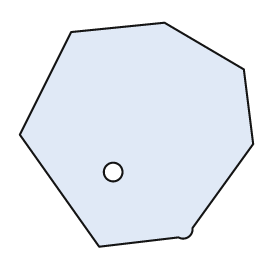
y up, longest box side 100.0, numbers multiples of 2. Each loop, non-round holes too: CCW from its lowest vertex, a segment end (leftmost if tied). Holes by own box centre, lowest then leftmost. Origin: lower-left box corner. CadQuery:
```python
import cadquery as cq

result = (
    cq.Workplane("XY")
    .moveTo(34.0, 0.0)
    .lineTo(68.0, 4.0)
    .threePointArc((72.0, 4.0), (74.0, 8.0))
    .lineTo(100.0, 44.0)
    .lineTo(96.0, 76.0)
    .lineTo(62.0, 96.0)
    .lineTo(22.0, 92.0)
    .lineTo(0.0, 48.0)
    .close()
    .moveTo(40.0, 32.0)
    .circle(4.0)
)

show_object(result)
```